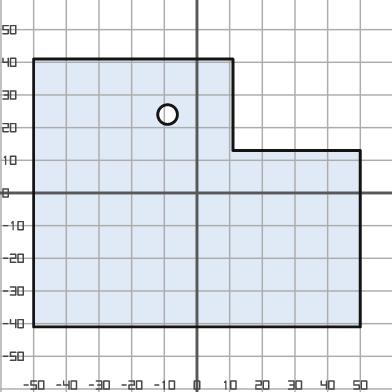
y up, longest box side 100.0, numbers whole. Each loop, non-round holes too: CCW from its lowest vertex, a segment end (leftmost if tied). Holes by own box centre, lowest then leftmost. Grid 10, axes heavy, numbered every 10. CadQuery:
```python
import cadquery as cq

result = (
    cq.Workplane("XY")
    .moveTo(-50.0, -41.0)
    .lineTo(50.0, -41.0)
    .lineTo(50.0, 13.0)
    .lineTo(11.0, 13.0)
    .lineTo(11.0, 41.0)
    .lineTo(-50.0, 41.0)
    .close()
    .moveTo(-9.0, 24.0)
    .circle(3.0)
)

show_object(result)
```